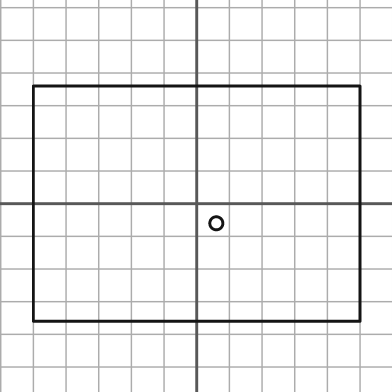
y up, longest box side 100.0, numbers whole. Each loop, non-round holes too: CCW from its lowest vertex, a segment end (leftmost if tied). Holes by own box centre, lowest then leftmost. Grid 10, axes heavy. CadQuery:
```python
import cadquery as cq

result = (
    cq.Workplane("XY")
    .moveTo(-50.0, -36.0)
    .lineTo(50.0, -36.0)
    .lineTo(50.0, 36.0)
    .lineTo(-50.0, 36.0)
    .close()
    .moveTo(6.0, -6.0)
    .circle(2.0)
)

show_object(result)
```